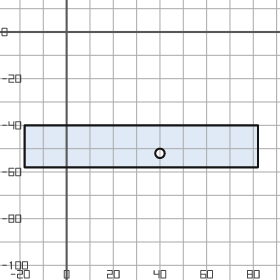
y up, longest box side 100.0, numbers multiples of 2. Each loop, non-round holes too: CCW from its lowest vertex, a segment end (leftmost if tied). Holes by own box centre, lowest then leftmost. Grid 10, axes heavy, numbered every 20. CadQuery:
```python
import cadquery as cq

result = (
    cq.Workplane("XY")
    .moveTo(-18.0, -58.0)
    .lineTo(82.0, -58.0)
    .lineTo(82.0, -40.0)
    .lineTo(-18.0, -40.0)
    .close()
    .moveTo(40.0, -52.0)
    .circle(2.0)
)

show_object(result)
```